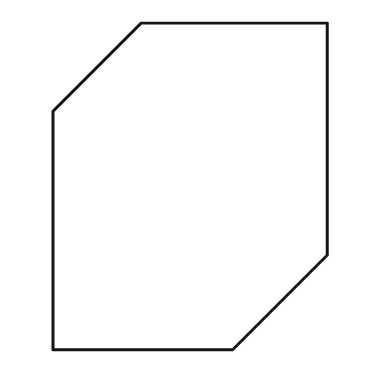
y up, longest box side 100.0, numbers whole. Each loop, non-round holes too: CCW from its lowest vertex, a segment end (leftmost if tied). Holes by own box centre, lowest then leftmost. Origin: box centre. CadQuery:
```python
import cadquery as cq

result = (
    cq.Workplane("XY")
    .moveTo(-42.0, -50.0)
    .lineTo(13.0, -50.0)
    .lineTo(42.0, -21.0)
    .lineTo(42.0, 50.0)
    .lineTo(-15.0, 50.0)
    .lineTo(-42.0, 23.0)
    .close()
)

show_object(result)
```